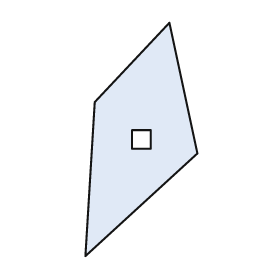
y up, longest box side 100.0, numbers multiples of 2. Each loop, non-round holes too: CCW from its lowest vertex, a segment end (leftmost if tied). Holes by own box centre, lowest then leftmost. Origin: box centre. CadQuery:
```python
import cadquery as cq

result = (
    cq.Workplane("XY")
    .moveTo(-24.0, -50.0)
    .lineTo(24.0, -6.0)
    .lineTo(12.0, 50.0)
    .lineTo(-20.0, 16.0)
    .close()
    .moveTo(-4.0, -4.0)
    .lineTo(4.0, -4.0)
    .lineTo(4.0, 4.0)
    .lineTo(-4.0, 4.0)
    .close()
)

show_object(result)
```